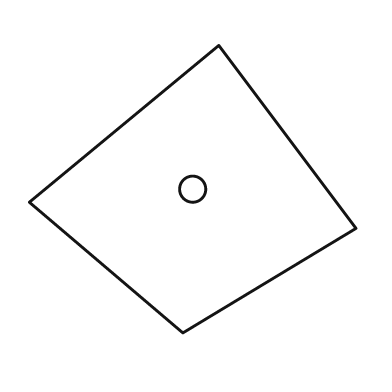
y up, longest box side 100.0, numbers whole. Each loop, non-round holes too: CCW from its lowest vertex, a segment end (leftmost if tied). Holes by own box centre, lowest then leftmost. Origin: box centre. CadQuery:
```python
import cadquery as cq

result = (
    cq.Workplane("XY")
    .moveTo(-3.0, -44.0)
    .lineTo(50.0, -12.0)
    .lineTo(8.0, 44.0)
    .lineTo(-50.0, -4.0)
    .close()
    .moveTo(0.0, 0.0)
    .circle(4.0)
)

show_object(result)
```